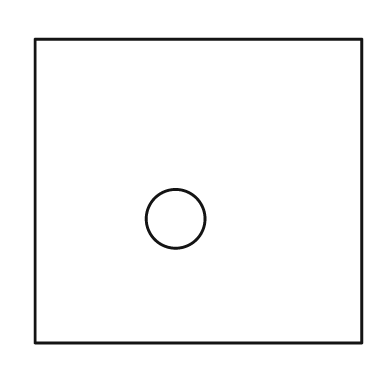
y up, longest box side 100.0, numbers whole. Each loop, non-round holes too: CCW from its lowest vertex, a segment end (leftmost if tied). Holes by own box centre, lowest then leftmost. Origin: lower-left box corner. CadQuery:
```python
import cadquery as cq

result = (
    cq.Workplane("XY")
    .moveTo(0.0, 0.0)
    .lineTo(100.0, 0.0)
    .lineTo(100.0, 93.0)
    .lineTo(0.0, 93.0)
    .close()
    .moveTo(43.0, 38.0)
    .circle(9.0)
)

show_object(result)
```